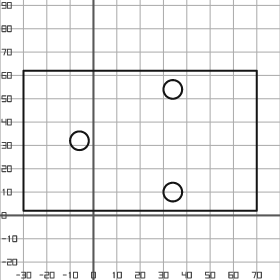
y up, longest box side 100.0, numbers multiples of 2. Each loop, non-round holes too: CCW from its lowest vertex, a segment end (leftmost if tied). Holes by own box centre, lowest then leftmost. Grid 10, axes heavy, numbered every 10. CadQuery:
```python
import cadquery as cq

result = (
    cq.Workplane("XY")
    .moveTo(-30.0, 2.0)
    .lineTo(70.0, 2.0)
    .lineTo(70.0, 62.0)
    .lineTo(-30.0, 62.0)
    .close()
    .moveTo(34.0, 10.0)
    .circle(4.0)
    .moveTo(-6.0, 32.0)
    .circle(4.0)
    .moveTo(34.0, 54.0)
    .circle(4.0)
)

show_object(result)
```